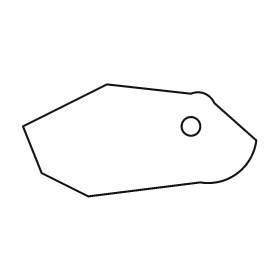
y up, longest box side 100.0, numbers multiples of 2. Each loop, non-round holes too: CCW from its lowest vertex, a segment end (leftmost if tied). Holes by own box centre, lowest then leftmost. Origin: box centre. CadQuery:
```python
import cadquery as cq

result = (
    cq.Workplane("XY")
    .moveTo(-22.0, -24.0)
    .lineTo(26.0, -18.0)
    .threePointArc((42.0, -14.0), (50.0, 0.0))
    .lineTo(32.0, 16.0)
    .threePointArc((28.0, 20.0), (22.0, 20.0))
    .lineTo(-14.0, 24.0)
    .lineTo(-50.0, 6.0)
    .lineTo(-42.0, -14.0)
    .close()
    .moveTo(22.0, 6.0)
    .circle(4.0)
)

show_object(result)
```